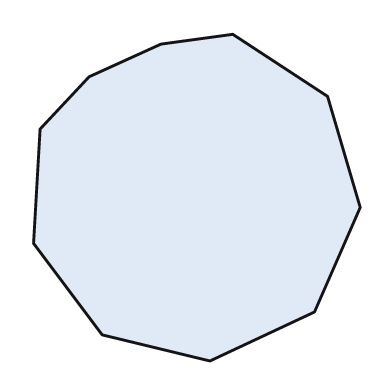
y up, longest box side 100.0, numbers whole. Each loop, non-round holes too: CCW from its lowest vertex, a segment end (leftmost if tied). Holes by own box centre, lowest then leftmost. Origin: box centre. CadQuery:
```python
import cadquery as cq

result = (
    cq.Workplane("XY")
    .moveTo(4.0, -50.0)
    .lineTo(36.0, -35.0)
    .lineTo(50.0, -3.0)
    .lineTo(40.0, 31.0)
    .lineTo(11.0, 50.0)
    .lineTo(-11.0, 47.0)
    .lineTo(-33.0, 37.0)
    .lineTo(-48.0, 21.0)
    .lineTo(-50.0, -14.0)
    .lineTo(-29.0, -42.0)
    .close()
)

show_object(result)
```